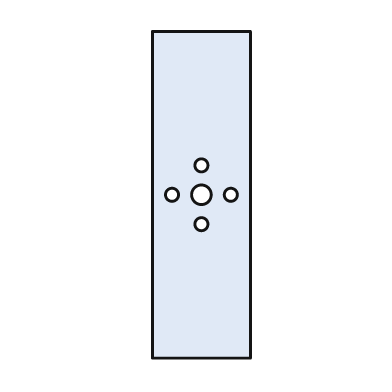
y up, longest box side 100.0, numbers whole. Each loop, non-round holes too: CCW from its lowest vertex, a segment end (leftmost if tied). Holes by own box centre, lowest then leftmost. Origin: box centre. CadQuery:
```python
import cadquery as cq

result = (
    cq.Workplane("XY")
    .moveTo(-15.0, -50.0)
    .lineTo(15.0, -50.0)
    .lineTo(15.0, 50.0)
    .lineTo(-15.0, 50.0)
    .close()
    .moveTo(0.0, -9.0)
    .circle(2.0)
    .moveTo(-9.0, 0.0)
    .circle(2.0)
    .moveTo(0.0, 0.0)
    .circle(3.0)
    .moveTo(9.0, 0.0)
    .circle(2.0)
    .moveTo(0.0, 9.0)
    .circle(2.0)
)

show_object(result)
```